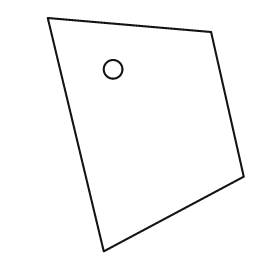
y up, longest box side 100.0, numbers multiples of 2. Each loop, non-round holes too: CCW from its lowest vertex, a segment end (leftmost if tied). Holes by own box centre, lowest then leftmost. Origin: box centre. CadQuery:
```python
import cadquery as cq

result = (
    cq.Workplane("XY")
    .moveTo(-18.0, -50.0)
    .lineTo(42.0, -18.0)
    .lineTo(28.0, 44.0)
    .lineTo(-42.0, 50.0)
    .close()
    .moveTo(-14.0, 28.0)
    .circle(4.0)
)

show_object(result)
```